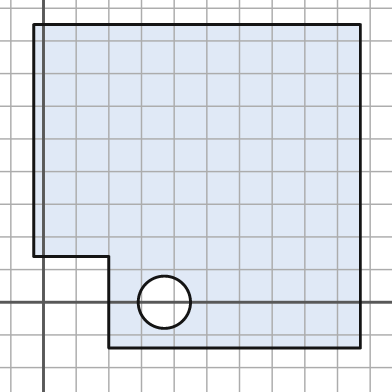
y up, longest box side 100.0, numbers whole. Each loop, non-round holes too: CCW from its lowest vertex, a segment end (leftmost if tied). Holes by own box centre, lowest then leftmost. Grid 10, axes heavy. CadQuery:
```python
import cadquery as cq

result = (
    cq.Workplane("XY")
    .moveTo(20.0, -14.0)
    .lineTo(97.0, -14.0)
    .lineTo(97.0, 85.0)
    .lineTo(-3.0, 85.0)
    .lineTo(-3.0, 14.0)
    .lineTo(20.0, 14.0)
    .close()
    .moveTo(37.0, 0.0)
    .circle(8.0)
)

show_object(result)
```